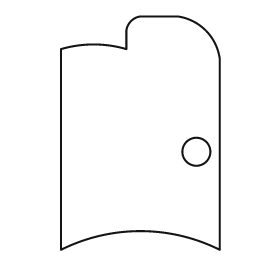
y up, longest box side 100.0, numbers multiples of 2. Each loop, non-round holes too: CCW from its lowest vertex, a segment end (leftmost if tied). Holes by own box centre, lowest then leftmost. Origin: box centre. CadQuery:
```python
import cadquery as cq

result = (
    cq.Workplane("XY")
    .moveTo(-34.0, -50.0)
    .threePointArc((0.0, -42.0), (34.0, -50.0))
    .lineTo(34.0, 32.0)
    .threePointArc((28.0, 44.0), (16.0, 50.0))
    .lineTo(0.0, 50.0)
    .threePointArc((-4.0, 48.0), (-6.0, 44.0))
    .lineTo(-6.0, 36.0)
    .threePointArc((-20.0, 38.0), (-34.0, 36.0))
    .close()
    .moveTo(24.0, -8.0)
    .circle(6.0)
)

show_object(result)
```